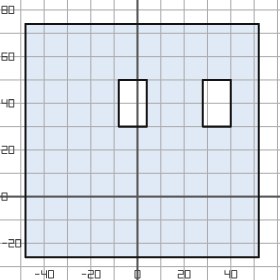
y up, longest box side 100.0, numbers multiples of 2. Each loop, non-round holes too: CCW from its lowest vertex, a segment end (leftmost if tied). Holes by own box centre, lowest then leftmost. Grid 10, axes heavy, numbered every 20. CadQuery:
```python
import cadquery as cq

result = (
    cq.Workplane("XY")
    .moveTo(-48.0, -26.0)
    .lineTo(52.0, -26.0)
    .lineTo(52.0, 74.0)
    .lineTo(-48.0, 74.0)
    .close()
    .moveTo(-8.0, 30.0)
    .lineTo(4.0, 30.0)
    .lineTo(4.0, 50.0)
    .lineTo(-8.0, 50.0)
    .close()
    .moveTo(28.0, 30.0)
    .lineTo(40.0, 30.0)
    .lineTo(40.0, 50.0)
    .lineTo(28.0, 50.0)
    .close()
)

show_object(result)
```